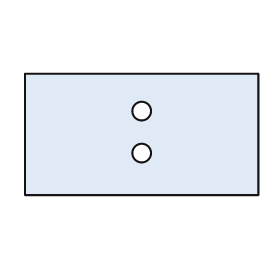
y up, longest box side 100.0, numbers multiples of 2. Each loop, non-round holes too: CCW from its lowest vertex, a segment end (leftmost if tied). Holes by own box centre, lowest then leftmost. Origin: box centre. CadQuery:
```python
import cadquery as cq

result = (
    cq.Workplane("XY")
    .moveTo(-50.0, -26.0)
    .lineTo(50.0, -26.0)
    .lineTo(50.0, 26.0)
    .lineTo(-50.0, 26.0)
    .close()
    .moveTo(0.0, -8.0)
    .circle(4.0)
    .moveTo(0.0, 10.0)
    .circle(4.0)
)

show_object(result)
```